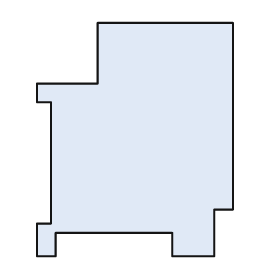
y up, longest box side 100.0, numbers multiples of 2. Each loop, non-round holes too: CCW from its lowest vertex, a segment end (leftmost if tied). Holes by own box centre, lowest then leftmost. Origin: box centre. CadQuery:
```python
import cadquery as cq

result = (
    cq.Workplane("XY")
    .moveTo(-42.0, -50.0)
    .lineTo(-34.0, -50.0)
    .lineTo(-34.0, -40.0)
    .lineTo(16.0, -40.0)
    .lineTo(16.0, -50.0)
    .lineTo(34.0, -50.0)
    .lineTo(34.0, -30.0)
    .lineTo(42.0, -30.0)
    .lineTo(42.0, 50.0)
    .lineTo(-16.0, 50.0)
    .lineTo(-16.0, 24.0)
    .lineTo(-42.0, 24.0)
    .lineTo(-42.0, 16.0)
    .lineTo(-36.0, 16.0)
    .lineTo(-36.0, -36.0)
    .lineTo(-42.0, -36.0)
    .close()
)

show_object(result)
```